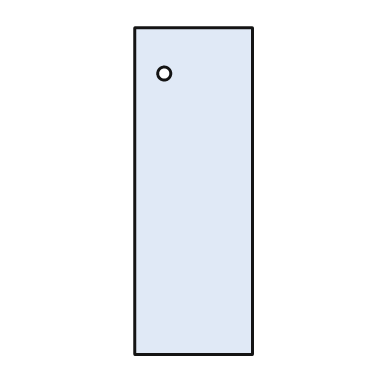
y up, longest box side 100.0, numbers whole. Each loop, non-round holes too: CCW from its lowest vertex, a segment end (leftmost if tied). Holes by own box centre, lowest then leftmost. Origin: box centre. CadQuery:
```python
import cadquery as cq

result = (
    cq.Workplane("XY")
    .moveTo(-18.0, -50.0)
    .lineTo(18.0, -50.0)
    .lineTo(18.0, 50.0)
    .lineTo(-18.0, 50.0)
    .close()
    .moveTo(-9.0, 36.0)
    .circle(2.0)
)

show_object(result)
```